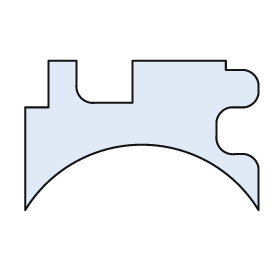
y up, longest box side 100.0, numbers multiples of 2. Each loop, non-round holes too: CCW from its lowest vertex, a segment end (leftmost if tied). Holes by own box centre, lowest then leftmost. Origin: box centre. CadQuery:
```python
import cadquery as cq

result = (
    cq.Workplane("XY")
    .moveTo(-50.0, -32.0)
    .threePointArc((0.0, -4.0), (50.0, -32.0))
    .lineTo(50.0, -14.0)
    .threePointArc((48.0, -10.0), (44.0, -8.0))
    .lineTo(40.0, -8.0)
    .threePointArc((34.0, -6.0), (32.0, 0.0))
    .lineTo(32.0, 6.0)
    .threePointArc((34.0, 10.0), (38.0, 12.0))
    .lineTo(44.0, 12.0)
    .threePointArc((48.0, 14.0), (50.0, 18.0))
    .lineTo(50.0, 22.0)
    .threePointArc((48.0, 26.0), (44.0, 28.0))
    .lineTo(36.0, 28.0)
    .lineTo(36.0, 32.0)
    .lineTo(-4.0, 32.0)
    .lineTo(-4.0, 14.0)
    .lineTo(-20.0, 14.0)
    .threePointArc((-26.0, 16.0), (-28.0, 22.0))
    .lineTo(-28.0, 32.0)
    .lineTo(-40.0, 32.0)
    .lineTo(-40.0, 12.0)
    .lineTo(-50.0, 12.0)
    .close()
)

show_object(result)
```